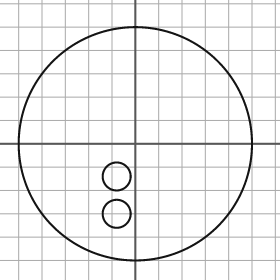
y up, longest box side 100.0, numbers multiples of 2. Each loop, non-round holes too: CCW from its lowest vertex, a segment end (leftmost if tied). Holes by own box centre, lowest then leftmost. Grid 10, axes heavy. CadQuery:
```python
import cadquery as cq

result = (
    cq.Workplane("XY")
    .moveTo(0.0, 0.0)
    .circle(50.0)
    .moveTo(-8.0, -30.0)
    .circle(6.0)
    .moveTo(-8.0, -14.0)
    .circle(6.0)
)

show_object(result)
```